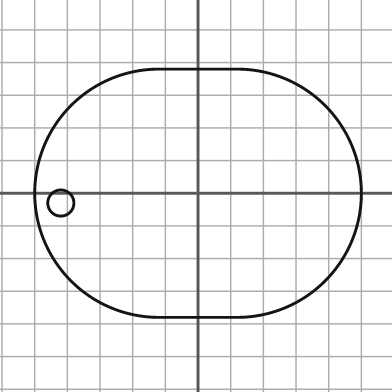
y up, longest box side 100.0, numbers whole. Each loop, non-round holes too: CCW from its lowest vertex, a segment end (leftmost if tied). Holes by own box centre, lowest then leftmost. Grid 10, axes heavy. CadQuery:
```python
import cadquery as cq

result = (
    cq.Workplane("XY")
    .moveTo(-12.0, -38.0)
    .lineTo(12.0, -38.0)
    .threePointArc((50.0, 0.0), (12.0, 38.0))
    .lineTo(-12.0, 38.0)
    .threePointArc((-50.0, 0.0), (-12.0, -38.0))
    .close()
    .moveTo(-42.0, -3.0)
    .circle(4.0)
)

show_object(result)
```